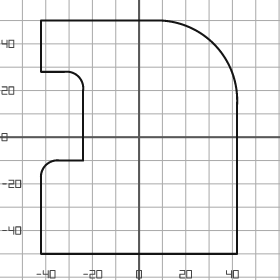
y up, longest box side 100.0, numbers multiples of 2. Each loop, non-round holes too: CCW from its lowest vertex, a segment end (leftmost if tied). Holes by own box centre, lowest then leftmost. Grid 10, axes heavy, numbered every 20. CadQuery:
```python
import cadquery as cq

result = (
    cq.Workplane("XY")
    .moveTo(-42.0, -50.0)
    .lineTo(42.0, -50.0)
    .lineTo(42.0, 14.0)
    .threePointArc((32.0, 40.0), (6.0, 50.0))
    .lineTo(-42.0, 50.0)
    .lineTo(-42.0, 28.0)
    .lineTo(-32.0, 28.0)
    .threePointArc((-26.0, 26.0), (-24.0, 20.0))
    .lineTo(-24.0, -10.0)
    .lineTo(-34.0, -10.0)
    .threePointArc((-40.0, -12.0), (-42.0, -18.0))
    .close()
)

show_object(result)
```